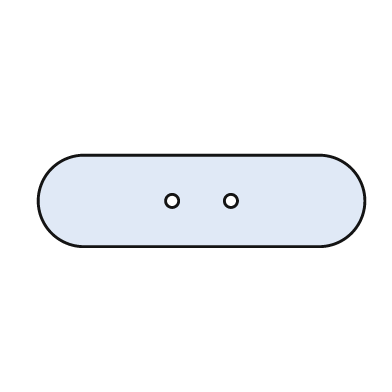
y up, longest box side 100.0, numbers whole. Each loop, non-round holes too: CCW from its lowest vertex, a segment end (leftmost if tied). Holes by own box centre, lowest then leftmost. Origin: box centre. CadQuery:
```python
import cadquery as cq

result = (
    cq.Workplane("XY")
    .moveTo(-36.0, -14.0)
    .lineTo(36.0, -14.0)
    .threePointArc((50.0, 0.0), (36.0, 14.0))
    .lineTo(-36.0, 14.0)
    .threePointArc((-50.0, 0.0), (-36.0, -14.0))
    .close()
    .moveTo(-9.0, 0.0)
    .circle(2.0)
    .moveTo(9.0, 0.0)
    .circle(2.0)
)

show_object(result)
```